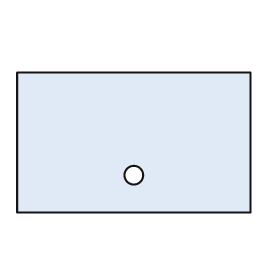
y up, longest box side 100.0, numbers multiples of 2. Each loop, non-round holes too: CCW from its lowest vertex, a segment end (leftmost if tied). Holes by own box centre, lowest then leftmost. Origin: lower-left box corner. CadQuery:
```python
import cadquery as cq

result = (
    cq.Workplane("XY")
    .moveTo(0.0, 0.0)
    .lineTo(100.0, 0.0)
    .lineTo(100.0, 60.0)
    .lineTo(0.0, 60.0)
    .close()
    .moveTo(50.0, 16.0)
    .circle(4.0)
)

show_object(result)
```